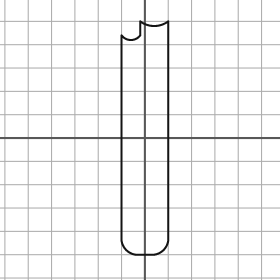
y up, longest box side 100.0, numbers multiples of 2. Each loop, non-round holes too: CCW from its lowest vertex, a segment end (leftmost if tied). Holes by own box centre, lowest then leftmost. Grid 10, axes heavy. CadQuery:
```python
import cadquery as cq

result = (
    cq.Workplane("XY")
    .moveTo(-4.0, -50.0)
    .lineTo(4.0, -50.0)
    .threePointArc((8.0, -48.0), (10.0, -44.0))
    .lineTo(10.0, 50.0)
    .threePointArc((4.0, 48.0), (-2.0, 50.0))
    .lineTo(-2.0, 44.0)
    .threePointArc((-6.0, 42.0), (-10.0, 44.0))
    .lineTo(-10.0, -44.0)
    .threePointArc((-8.0, -48.0), (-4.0, -50.0))
    .close()
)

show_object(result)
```